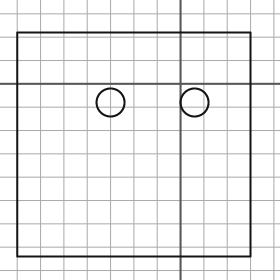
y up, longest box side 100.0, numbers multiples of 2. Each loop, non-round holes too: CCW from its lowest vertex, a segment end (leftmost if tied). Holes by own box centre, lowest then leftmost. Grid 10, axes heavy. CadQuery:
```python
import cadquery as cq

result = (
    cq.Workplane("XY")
    .moveTo(-70.0, -74.0)
    .lineTo(30.0, -74.0)
    .lineTo(30.0, 22.0)
    .lineTo(-70.0, 22.0)
    .close()
    .moveTo(-30.0, -8.0)
    .circle(6.0)
    .moveTo(6.0, -8.0)
    .circle(6.0)
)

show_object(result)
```